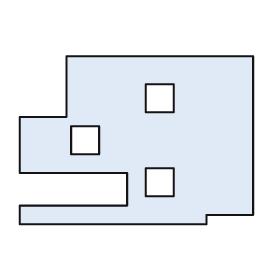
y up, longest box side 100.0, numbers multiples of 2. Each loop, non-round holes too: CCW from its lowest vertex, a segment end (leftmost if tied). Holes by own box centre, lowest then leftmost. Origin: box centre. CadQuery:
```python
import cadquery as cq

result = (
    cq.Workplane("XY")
    .moveTo(-50.0, -36.0)
    .lineTo(30.0, -36.0)
    .lineTo(30.0, -32.0)
    .lineTo(50.0, -32.0)
    .lineTo(50.0, 36.0)
    .lineTo(-30.0, 36.0)
    .lineTo(-30.0, 10.0)
    .lineTo(-50.0, 10.0)
    .lineTo(-50.0, -14.0)
    .lineTo(-4.0, -14.0)
    .lineTo(-4.0, -28.0)
    .lineTo(-50.0, -28.0)
    .close()
    .moveTo(4.0, -24.0)
    .lineTo(16.0, -24.0)
    .lineTo(16.0, -12.0)
    .lineTo(4.0, -12.0)
    .close()
    .moveTo(-28.0, -6.0)
    .lineTo(-16.0, -6.0)
    .lineTo(-16.0, 6.0)
    .lineTo(-28.0, 6.0)
    .close()
    .moveTo(4.0, 12.0)
    .lineTo(16.0, 12.0)
    .lineTo(16.0, 24.0)
    .lineTo(4.0, 24.0)
    .close()
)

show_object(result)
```